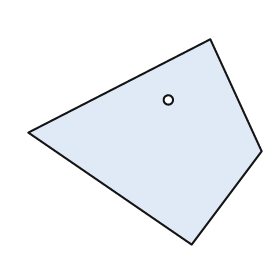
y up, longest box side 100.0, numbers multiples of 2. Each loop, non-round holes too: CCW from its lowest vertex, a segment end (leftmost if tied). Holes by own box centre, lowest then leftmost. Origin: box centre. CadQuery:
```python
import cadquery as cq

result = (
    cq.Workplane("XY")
    .moveTo(20.0, -44.0)
    .lineTo(50.0, -4.0)
    .lineTo(28.0, 44.0)
    .lineTo(-50.0, 4.0)
    .close()
    .moveTo(10.0, 18.0)
    .circle(2.0)
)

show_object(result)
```